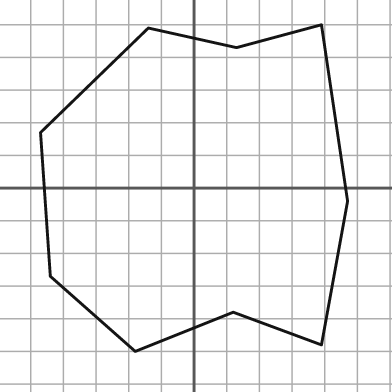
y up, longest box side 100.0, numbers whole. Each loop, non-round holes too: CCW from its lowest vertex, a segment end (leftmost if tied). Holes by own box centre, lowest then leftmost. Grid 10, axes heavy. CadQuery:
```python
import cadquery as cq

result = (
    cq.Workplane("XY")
    .moveTo(-18.0, -50.0)
    .lineTo(12.0, -38.0)
    .lineTo(39.0, -48.0)
    .lineTo(47.0, -4.0)
    .lineTo(39.0, 50.0)
    .lineTo(13.0, 43.0)
    .lineTo(-14.0, 49.0)
    .lineTo(-47.0, 17.0)
    .lineTo(-44.0, -27.0)
    .close()
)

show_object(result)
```